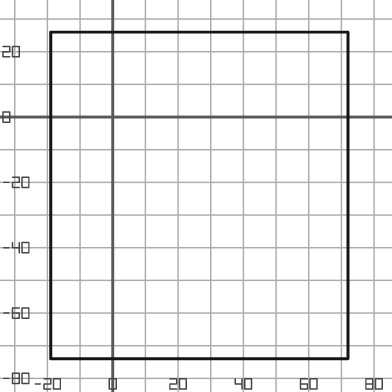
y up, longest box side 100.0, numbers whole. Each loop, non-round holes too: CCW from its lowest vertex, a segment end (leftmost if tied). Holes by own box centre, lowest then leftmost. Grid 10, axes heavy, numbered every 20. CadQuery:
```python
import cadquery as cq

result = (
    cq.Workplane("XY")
    .moveTo(-19.0, -74.0)
    .lineTo(72.0, -74.0)
    .lineTo(72.0, 26.0)
    .lineTo(-19.0, 26.0)
    .close()
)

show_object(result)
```